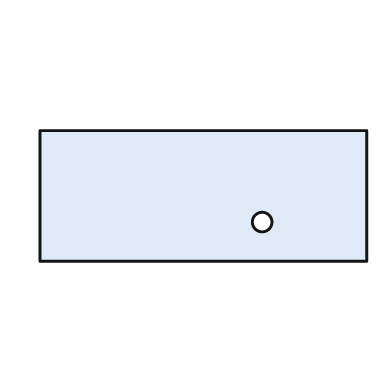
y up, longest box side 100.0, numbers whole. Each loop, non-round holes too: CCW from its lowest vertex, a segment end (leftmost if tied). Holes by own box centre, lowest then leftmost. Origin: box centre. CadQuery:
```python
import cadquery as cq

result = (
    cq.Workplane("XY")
    .moveTo(-50.0, -20.0)
    .lineTo(50.0, -20.0)
    .lineTo(50.0, 20.0)
    .lineTo(-50.0, 20.0)
    .close()
    .moveTo(18.0, -8.0)
    .circle(3.0)
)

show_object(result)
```